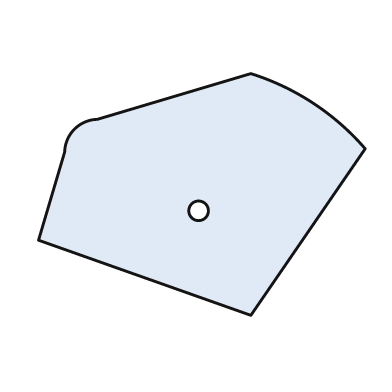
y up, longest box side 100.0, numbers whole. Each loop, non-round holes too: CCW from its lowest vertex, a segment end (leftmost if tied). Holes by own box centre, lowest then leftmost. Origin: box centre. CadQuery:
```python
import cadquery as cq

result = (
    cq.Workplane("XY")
    .moveTo(15.0, -37.0)
    .lineTo(50.0, 14.0)
    .threePointArc((34.0, 28.0), (15.0, 37.0))
    .lineTo(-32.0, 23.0)
    .threePointArc((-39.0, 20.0), (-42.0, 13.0))
    .lineTo(-50.0, -14.0)
    .close()
    .moveTo(-1.0, -5.0)
    .circle(3.0)
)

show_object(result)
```